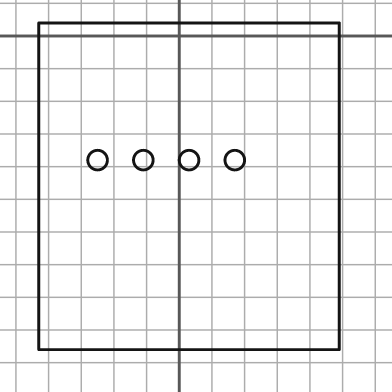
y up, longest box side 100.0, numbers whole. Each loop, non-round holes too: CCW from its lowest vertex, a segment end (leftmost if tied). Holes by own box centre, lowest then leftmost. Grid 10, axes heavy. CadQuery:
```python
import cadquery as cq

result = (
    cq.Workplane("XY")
    .moveTo(-43.0, -96.0)
    .lineTo(49.0, -96.0)
    .lineTo(49.0, 4.0)
    .lineTo(-43.0, 4.0)
    .close()
    .moveTo(-25.0, -38.0)
    .circle(3.0)
    .moveTo(-11.0, -38.0)
    .circle(3.0)
    .moveTo(3.0, -38.0)
    .circle(3.0)
    .moveTo(17.0, -38.0)
    .circle(3.0)
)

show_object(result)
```